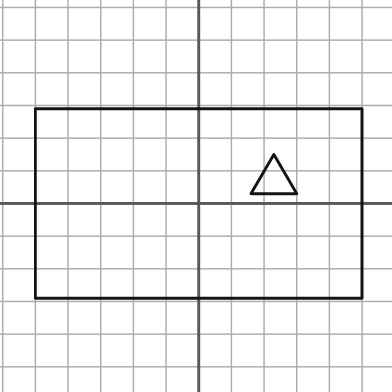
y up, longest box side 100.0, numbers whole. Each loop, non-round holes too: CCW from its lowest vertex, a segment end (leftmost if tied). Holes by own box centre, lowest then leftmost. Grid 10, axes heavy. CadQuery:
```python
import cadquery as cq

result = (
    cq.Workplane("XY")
    .moveTo(-50.0, -29.0)
    .lineTo(50.0, -29.0)
    .lineTo(50.0, 29.0)
    .lineTo(-50.0, 29.0)
    .close()
    .moveTo(16.0, 3.0)
    .lineTo(30.0, 3.0)
    .lineTo(23.0, 15.0)
    .close()
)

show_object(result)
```